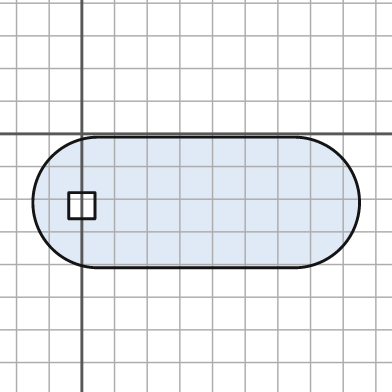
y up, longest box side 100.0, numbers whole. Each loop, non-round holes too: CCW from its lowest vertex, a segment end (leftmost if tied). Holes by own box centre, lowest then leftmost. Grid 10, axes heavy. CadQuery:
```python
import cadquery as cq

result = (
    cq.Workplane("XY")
    .moveTo(5.0, -41.0)
    .lineTo(65.0, -41.0)
    .threePointArc((85.0, -21.0), (65.0, -1.0))
    .lineTo(5.0, -1.0)
    .threePointArc((-15.0, -21.0), (5.0, -41.0))
    .close()
    .moveTo(-4.0, -26.0)
    .lineTo(4.0, -26.0)
    .lineTo(4.0, -18.0)
    .lineTo(-4.0, -18.0)
    .close()
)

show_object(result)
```